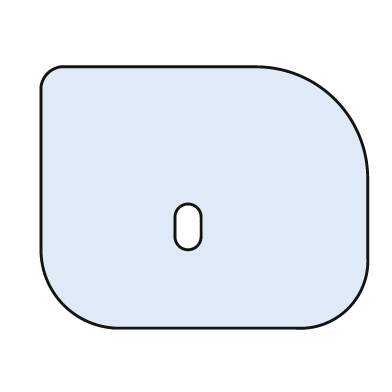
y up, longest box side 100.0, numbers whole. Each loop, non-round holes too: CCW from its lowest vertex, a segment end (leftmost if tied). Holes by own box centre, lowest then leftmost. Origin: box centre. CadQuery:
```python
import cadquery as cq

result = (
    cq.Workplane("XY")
    .moveTo(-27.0, -40.0)
    .lineTo(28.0, -40.0)
    .threePointArc((44.0, -34.0), (50.0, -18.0))
    .lineTo(50.0, 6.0)
    .threePointArc((40.0, 30.0), (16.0, 40.0))
    .lineTo(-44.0, 40.0)
    .threePointArc((-48.0, 38.0), (-50.0, 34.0))
    .lineTo(-50.0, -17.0)
    .threePointArc((-43.0, -33.0), (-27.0, -40.0))
    .close()
    .moveTo(-9.0, -12.0)
    .threePointArc((-5.0, -16.0), (-1.0, -12.0))
    .lineTo(-1.0, -6.0)
    .threePointArc((-5.0, -2.0), (-9.0, -6.0))
    .close()
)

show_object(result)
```